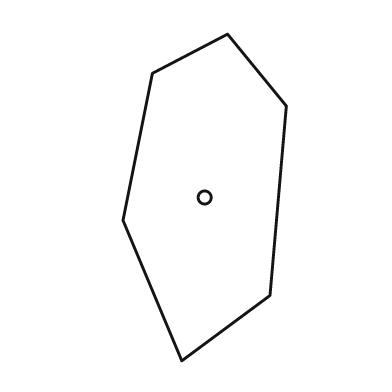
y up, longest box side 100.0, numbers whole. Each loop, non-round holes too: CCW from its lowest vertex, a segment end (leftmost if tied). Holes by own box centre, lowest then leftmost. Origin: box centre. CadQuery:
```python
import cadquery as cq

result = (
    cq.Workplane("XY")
    .moveTo(-7.0, -50.0)
    .lineTo(20.0, -30.0)
    .lineTo(25.0, 28.0)
    .lineTo(7.0, 50.0)
    .lineTo(-16.0, 38.0)
    .lineTo(-25.0, -7.0)
    .close()
    .moveTo(0.0, 0.0)
    .circle(2.0)
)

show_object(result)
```